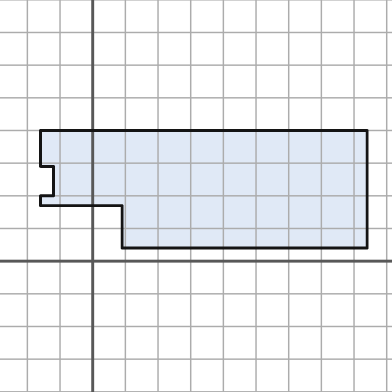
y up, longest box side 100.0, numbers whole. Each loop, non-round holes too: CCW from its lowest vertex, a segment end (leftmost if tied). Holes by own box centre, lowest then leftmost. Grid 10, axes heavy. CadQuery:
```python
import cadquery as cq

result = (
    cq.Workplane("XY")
    .moveTo(9.0, 4.0)
    .lineTo(84.0, 4.0)
    .lineTo(84.0, 40.0)
    .lineTo(-16.0, 40.0)
    .lineTo(-16.0, 29.0)
    .lineTo(-12.0, 29.0)
    .lineTo(-12.0, 20.0)
    .lineTo(-16.0, 20.0)
    .lineTo(-16.0, 17.0)
    .lineTo(9.0, 17.0)
    .close()
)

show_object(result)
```